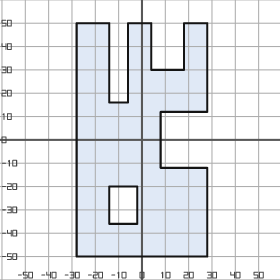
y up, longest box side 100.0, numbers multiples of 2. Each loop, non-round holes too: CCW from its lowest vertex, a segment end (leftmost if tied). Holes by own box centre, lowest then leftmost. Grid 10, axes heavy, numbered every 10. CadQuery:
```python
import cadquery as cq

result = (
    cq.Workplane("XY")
    .moveTo(-28.0, -50.0)
    .lineTo(28.0, -50.0)
    .lineTo(28.0, -12.0)
    .lineTo(8.0, -12.0)
    .lineTo(8.0, 12.0)
    .lineTo(28.0, 12.0)
    .lineTo(28.0, 50.0)
    .lineTo(18.0, 50.0)
    .lineTo(18.0, 30.0)
    .lineTo(4.0, 30.0)
    .lineTo(4.0, 50.0)
    .lineTo(-6.0, 50.0)
    .lineTo(-6.0, 16.0)
    .lineTo(-14.0, 16.0)
    .lineTo(-14.0, 50.0)
    .lineTo(-28.0, 50.0)
    .close()
    .moveTo(-14.0, -36.0)
    .lineTo(-2.0, -36.0)
    .lineTo(-2.0, -20.0)
    .lineTo(-14.0, -20.0)
    .close()
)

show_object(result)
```